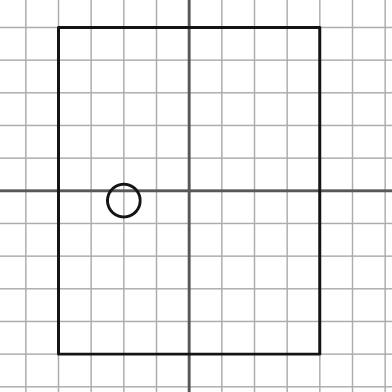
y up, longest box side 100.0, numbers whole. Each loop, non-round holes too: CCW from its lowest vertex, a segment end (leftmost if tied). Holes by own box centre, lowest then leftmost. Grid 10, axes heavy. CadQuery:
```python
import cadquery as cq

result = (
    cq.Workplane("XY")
    .moveTo(-40.0, -50.0)
    .lineTo(40.0, -50.0)
    .lineTo(40.0, 50.0)
    .lineTo(-40.0, 50.0)
    .close()
    .moveTo(-20.0, -3.0)
    .circle(5.0)
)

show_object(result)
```